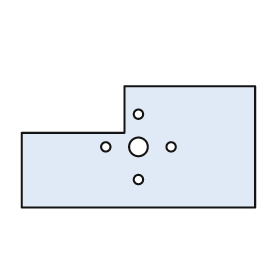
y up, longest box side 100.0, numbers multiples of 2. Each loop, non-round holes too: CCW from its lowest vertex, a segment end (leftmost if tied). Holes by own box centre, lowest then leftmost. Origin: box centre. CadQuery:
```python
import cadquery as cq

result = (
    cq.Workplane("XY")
    .moveTo(-50.0, -26.0)
    .lineTo(50.0, -26.0)
    .lineTo(50.0, 26.0)
    .lineTo(-6.0, 26.0)
    .lineTo(-6.0, 6.0)
    .lineTo(-50.0, 6.0)
    .close()
    .moveTo(0.0, -14.0)
    .circle(2.0)
    .moveTo(-14.0, 0.0)
    .circle(2.0)
    .moveTo(0.0, 0.0)
    .circle(4.0)
    .moveTo(14.0, 0.0)
    .circle(2.0)
    .moveTo(0.0, 14.0)
    .circle(2.0)
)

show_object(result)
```